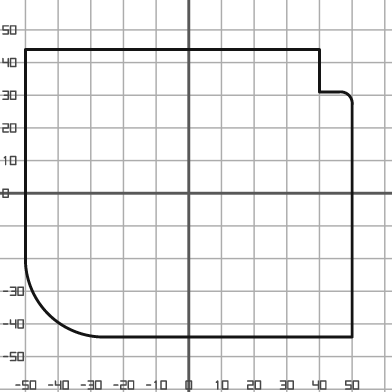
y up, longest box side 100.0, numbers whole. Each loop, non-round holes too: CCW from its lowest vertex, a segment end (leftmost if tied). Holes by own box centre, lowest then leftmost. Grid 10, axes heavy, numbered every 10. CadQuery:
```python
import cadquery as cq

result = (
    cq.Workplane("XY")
    .moveTo(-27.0, -44.0)
    .lineTo(50.0, -44.0)
    .lineTo(50.0, 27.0)
    .threePointArc((49.0, 30.0), (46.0, 31.0))
    .lineTo(40.0, 31.0)
    .lineTo(40.0, 44.0)
    .lineTo(-50.0, 44.0)
    .lineTo(-50.0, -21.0)
    .threePointArc((-43.0, -37.0), (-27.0, -44.0))
    .close()
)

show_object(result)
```